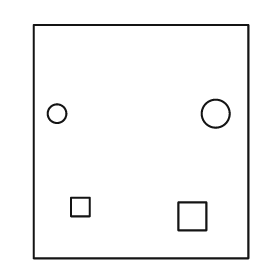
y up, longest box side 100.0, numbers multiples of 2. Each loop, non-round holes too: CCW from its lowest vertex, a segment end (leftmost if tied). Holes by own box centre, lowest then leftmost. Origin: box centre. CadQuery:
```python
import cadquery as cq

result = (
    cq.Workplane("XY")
    .moveTo(-46.0, -50.0)
    .lineTo(46.0, -50.0)
    .lineTo(46.0, 50.0)
    .lineTo(-46.0, 50.0)
    .close()
    .moveTo(16.0, -38.0)
    .lineTo(28.0, -38.0)
    .lineTo(28.0, -26.0)
    .lineTo(16.0, -26.0)
    .close()
    .moveTo(-30.0, -32.0)
    .lineTo(-22.0, -32.0)
    .lineTo(-22.0, -24.0)
    .lineTo(-30.0, -24.0)
    .close()
    .moveTo(-36.0, 12.0)
    .circle(4.0)
    .moveTo(32.0, 12.0)
    .circle(6.0)
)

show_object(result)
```